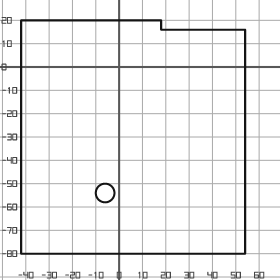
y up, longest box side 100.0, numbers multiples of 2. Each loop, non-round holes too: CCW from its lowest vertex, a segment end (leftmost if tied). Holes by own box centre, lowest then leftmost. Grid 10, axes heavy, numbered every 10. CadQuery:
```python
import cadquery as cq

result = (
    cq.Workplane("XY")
    .moveTo(-42.0, -80.0)
    .lineTo(54.0, -80.0)
    .lineTo(54.0, 16.0)
    .lineTo(18.0, 16.0)
    .lineTo(18.0, 20.0)
    .lineTo(-42.0, 20.0)
    .close()
    .moveTo(-6.0, -54.0)
    .circle(4.0)
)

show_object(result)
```